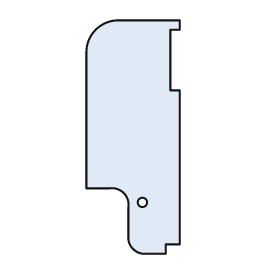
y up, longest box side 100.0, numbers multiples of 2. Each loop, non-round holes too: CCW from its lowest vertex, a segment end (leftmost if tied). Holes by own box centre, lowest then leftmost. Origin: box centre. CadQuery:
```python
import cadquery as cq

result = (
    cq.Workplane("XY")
    .moveTo(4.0, -50.0)
    .lineTo(14.0, -50.0)
    .lineTo(14.0, -46.0)
    .lineTo(20.0, -46.0)
    .lineTo(20.0, 20.0)
    .lineTo(16.0, 20.0)
    .lineTo(16.0, 46.0)
    .lineTo(20.0, 46.0)
    .lineTo(20.0, 50.0)
    .lineTo(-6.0, 50.0)
    .threePointArc((-16.0, 46.0), (-20.0, 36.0))
    .lineTo(-20.0, -22.0)
    .lineTo(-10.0, -22.0)
    .threePointArc((-4.0, -24.0), (-2.0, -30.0))
    .lineTo(-2.0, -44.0)
    .threePointArc((0.0, -48.0), (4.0, -50.0))
    .close()
    .moveTo(4.0, -28.0)
    .circle(2.0)
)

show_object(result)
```